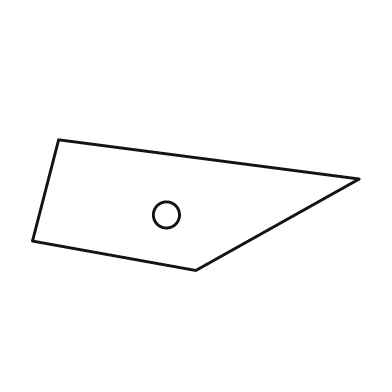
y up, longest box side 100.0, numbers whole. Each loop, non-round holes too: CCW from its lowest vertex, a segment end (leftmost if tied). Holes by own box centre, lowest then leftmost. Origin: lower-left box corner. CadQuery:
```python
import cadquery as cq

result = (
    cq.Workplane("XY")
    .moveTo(50.0, 0.0)
    .lineTo(100.0, 28.0)
    .lineTo(8.0, 40.0)
    .lineTo(0.0, 9.0)
    .close()
    .moveTo(41.0, 17.0)
    .circle(4.0)
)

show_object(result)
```